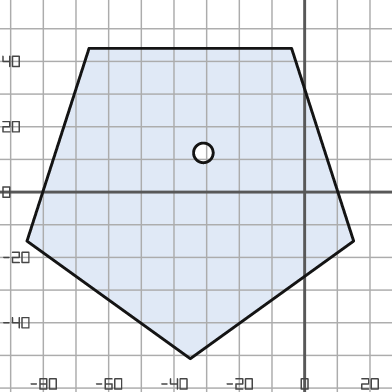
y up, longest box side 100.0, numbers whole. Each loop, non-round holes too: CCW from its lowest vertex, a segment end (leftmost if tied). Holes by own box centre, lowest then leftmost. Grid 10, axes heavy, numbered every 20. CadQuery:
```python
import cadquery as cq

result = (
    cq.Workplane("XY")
    .moveTo(-35.0, -51.0)
    .lineTo(15.0, -15.0)
    .lineTo(-4.0, 44.0)
    .lineTo(-66.0, 44.0)
    .lineTo(-85.0, -15.0)
    .close()
    .moveTo(-31.0, 12.0)
    .circle(3.0)
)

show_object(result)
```